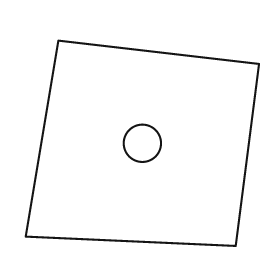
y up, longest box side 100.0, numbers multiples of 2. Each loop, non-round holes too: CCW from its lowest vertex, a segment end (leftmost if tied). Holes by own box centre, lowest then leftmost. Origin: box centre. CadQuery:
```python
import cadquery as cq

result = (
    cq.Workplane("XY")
    .moveTo(40.0, -44.0)
    .lineTo(50.0, 34.0)
    .lineTo(-36.0, 44.0)
    .lineTo(-50.0, -40.0)
    .close()
    .moveTo(0.0, 0.0)
    .circle(8.0)
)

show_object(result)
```